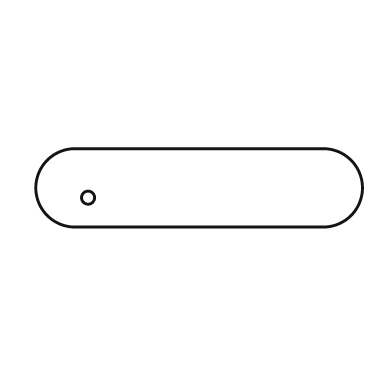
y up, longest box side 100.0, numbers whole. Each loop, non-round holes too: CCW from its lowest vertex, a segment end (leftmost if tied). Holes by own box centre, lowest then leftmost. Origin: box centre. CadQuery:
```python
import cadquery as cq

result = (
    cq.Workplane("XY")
    .moveTo(-38.0, -12.0)
    .lineTo(38.0, -12.0)
    .threePointArc((50.0, 0.0), (38.0, 12.0))
    .lineTo(-38.0, 12.0)
    .threePointArc((-50.0, 0.0), (-38.0, -12.0))
    .close()
    .moveTo(-34.0, -3.0)
    .circle(2.0)
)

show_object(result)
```